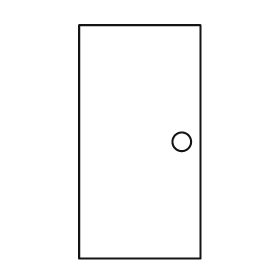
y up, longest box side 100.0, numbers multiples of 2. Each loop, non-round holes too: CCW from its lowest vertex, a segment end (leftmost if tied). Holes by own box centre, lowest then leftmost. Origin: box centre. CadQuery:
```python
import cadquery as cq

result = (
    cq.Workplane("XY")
    .moveTo(-26.0, -50.0)
    .lineTo(26.0, -50.0)
    .lineTo(26.0, 50.0)
    .lineTo(-26.0, 50.0)
    .close()
    .moveTo(18.0, 0.0)
    .circle(4.0)
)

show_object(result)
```